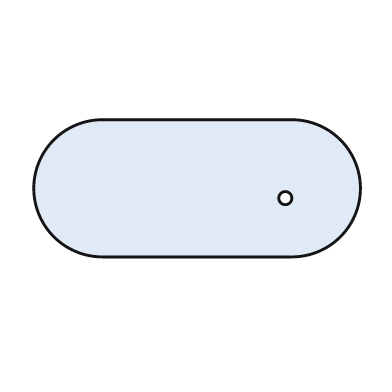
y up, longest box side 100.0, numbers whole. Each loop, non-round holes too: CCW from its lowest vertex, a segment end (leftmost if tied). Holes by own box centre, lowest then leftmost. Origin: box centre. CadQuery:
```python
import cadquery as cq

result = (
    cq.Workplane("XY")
    .moveTo(-29.0, -21.0)
    .lineTo(29.0, -21.0)
    .threePointArc((50.0, 0.0), (29.0, 21.0))
    .lineTo(-29.0, 21.0)
    .threePointArc((-50.0, 0.0), (-29.0, -21.0))
    .close()
    .moveTo(27.0, -3.0)
    .circle(2.0)
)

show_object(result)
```